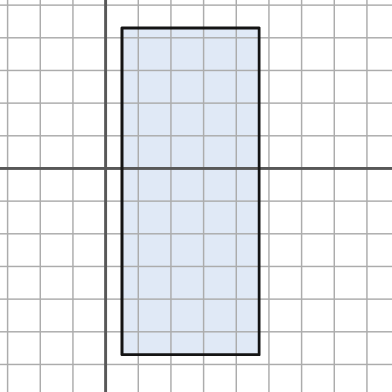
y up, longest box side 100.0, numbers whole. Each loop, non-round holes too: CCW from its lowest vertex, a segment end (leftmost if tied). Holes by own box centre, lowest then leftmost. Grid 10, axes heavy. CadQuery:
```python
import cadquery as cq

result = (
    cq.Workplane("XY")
    .moveTo(5.0, -57.0)
    .lineTo(47.0, -57.0)
    .lineTo(47.0, 43.0)
    .lineTo(5.0, 43.0)
    .close()
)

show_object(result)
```